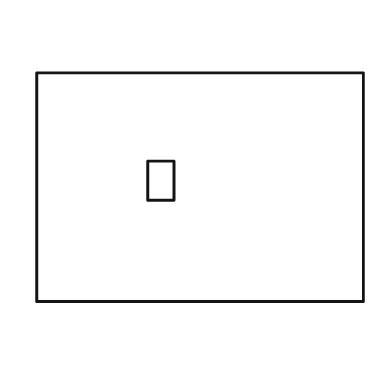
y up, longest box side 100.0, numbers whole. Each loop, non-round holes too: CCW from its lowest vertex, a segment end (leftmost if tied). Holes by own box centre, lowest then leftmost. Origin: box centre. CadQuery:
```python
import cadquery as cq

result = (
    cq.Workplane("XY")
    .moveTo(-50.0, -35.0)
    .lineTo(50.0, -35.0)
    .lineTo(50.0, 35.0)
    .lineTo(-50.0, 35.0)
    .close()
    .moveTo(-16.0, -4.0)
    .lineTo(-8.0, -4.0)
    .lineTo(-8.0, 8.0)
    .lineTo(-16.0, 8.0)
    .close()
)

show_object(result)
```